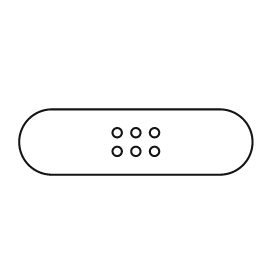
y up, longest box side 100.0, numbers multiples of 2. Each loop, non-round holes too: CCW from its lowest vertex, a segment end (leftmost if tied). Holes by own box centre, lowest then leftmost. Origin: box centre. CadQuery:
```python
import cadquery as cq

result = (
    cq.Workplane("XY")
    .moveTo(-36.0, -14.0)
    .lineTo(36.0, -14.0)
    .threePointArc((50.0, 0.0), (36.0, 14.0))
    .lineTo(-36.0, 14.0)
    .threePointArc((-50.0, 0.0), (-36.0, -14.0))
    .close()
    .moveTo(-8.0, -4.0)
    .circle(2.0)
    .moveTo(0.0, -4.0)
    .circle(2.0)
    .moveTo(8.0, -4.0)
    .circle(2.0)
    .moveTo(-8.0, 4.0)
    .circle(2.0)
    .moveTo(0.0, 4.0)
    .circle(2.0)
    .moveTo(8.0, 4.0)
    .circle(2.0)
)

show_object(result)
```